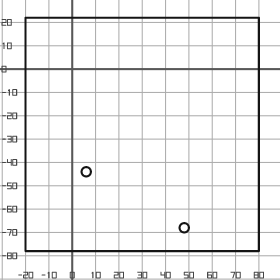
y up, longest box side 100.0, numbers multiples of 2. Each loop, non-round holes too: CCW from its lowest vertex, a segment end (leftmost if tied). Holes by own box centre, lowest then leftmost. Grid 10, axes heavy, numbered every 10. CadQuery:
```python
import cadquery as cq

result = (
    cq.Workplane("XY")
    .moveTo(-20.0, -78.0)
    .lineTo(80.0, -78.0)
    .lineTo(80.0, 22.0)
    .lineTo(-20.0, 22.0)
    .close()
    .moveTo(48.0, -68.0)
    .circle(2.0)
    .moveTo(6.0, -44.0)
    .circle(2.0)
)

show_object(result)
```